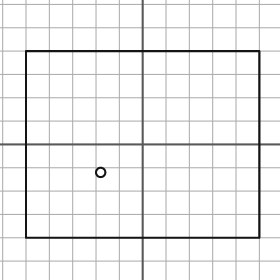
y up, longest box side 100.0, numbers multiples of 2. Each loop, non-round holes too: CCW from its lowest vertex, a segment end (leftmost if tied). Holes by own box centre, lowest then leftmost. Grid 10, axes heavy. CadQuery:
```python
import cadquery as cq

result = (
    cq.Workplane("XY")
    .moveTo(-50.0, -40.0)
    .lineTo(50.0, -40.0)
    .lineTo(50.0, 40.0)
    .lineTo(-50.0, 40.0)
    .close()
    .moveTo(-18.0, -12.0)
    .circle(2.0)
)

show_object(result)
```